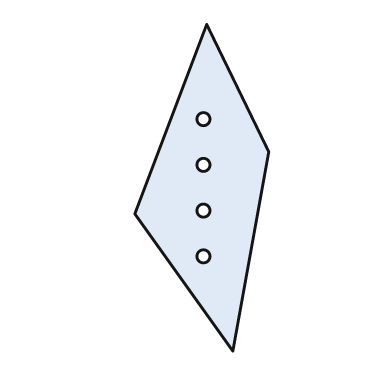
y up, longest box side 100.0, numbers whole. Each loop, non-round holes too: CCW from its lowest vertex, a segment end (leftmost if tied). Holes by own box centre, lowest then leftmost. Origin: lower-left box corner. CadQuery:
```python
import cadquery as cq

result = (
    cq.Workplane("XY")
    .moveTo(30.0, 0.0)
    .lineTo(41.0, 61.0)
    .lineTo(22.0, 100.0)
    .lineTo(0.0, 42.0)
    .close()
    .moveTo(21.0, 29.0)
    .circle(2.0)
    .moveTo(21.0, 43.0)
    .circle(2.0)
    .moveTo(21.0, 57.0)
    .circle(2.0)
    .moveTo(21.0, 71.0)
    .circle(2.0)
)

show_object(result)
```